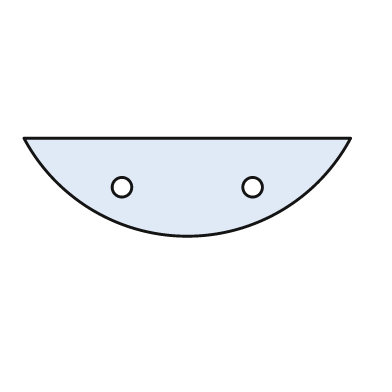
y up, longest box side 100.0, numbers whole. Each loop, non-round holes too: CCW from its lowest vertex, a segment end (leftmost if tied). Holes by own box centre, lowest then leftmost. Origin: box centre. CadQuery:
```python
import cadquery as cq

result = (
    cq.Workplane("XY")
    .moveTo(-50.0, 15.0)
    .threePointArc((0.0, -15.0), (50.0, 15.0))
    .close()
    .moveTo(-20.0, 0.0)
    .circle(3.0)
    .moveTo(20.0, 0.0)
    .circle(3.0)
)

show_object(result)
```